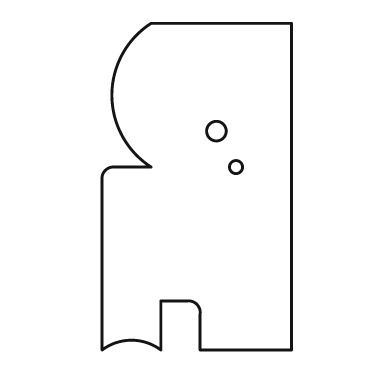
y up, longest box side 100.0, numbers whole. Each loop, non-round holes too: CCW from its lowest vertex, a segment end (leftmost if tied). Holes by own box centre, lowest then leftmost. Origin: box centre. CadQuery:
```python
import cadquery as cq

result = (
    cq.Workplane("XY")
    .moveTo(-29.0, -50.0)
    .threePointArc((-20.0, -47.0), (-11.0, -50.0))
    .lineTo(-11.0, -35.0)
    .lineTo(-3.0, -35.0)
    .threePointArc((0.0, -36.0), (1.0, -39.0))
    .lineTo(1.0, -50.0)
    .lineTo(29.0, -50.0)
    .lineTo(29.0, 50.0)
    .lineTo(-14.0, 50.0)
    .threePointArc((-26.0, 28.0), (-14.0, 6.0))
    .lineTo(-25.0, 6.0)
    .threePointArc((-28.0, 5.0), (-29.0, 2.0))
    .close()
    .moveTo(12.0, 6.0)
    .circle(2.0)
    .moveTo(6.0, 17.0)
    .circle(3.0)
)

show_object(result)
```